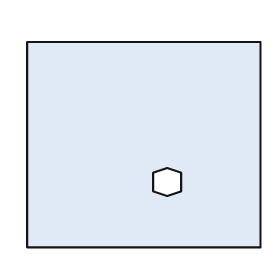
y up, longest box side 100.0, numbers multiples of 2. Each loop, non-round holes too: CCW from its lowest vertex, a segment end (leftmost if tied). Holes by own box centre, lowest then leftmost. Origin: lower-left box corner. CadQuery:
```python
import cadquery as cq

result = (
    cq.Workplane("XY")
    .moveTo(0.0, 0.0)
    .lineTo(100.0, 0.0)
    .lineTo(100.0, 88.0)
    .lineTo(0.0, 88.0)
    .close()
    .moveTo(60.0, 22.0)
    .lineTo(66.0, 24.0)
    .lineTo(66.0, 32.0)
    .lineTo(60.0, 34.0)
    .lineTo(54.0, 32.0)
    .lineTo(54.0, 24.0)
    .close()
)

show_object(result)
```